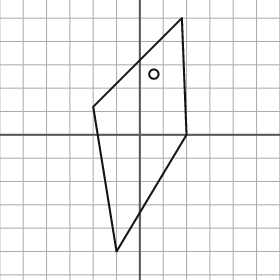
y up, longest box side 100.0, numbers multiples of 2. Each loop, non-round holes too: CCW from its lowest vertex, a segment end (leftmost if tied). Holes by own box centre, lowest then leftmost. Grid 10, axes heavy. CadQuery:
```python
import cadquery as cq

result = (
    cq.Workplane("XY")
    .moveTo(-10.0, -50.0)
    .lineTo(20.0, 0.0)
    .lineTo(18.0, 50.0)
    .lineTo(-20.0, 12.0)
    .close()
    .moveTo(6.0, 26.0)
    .circle(2.0)
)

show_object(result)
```